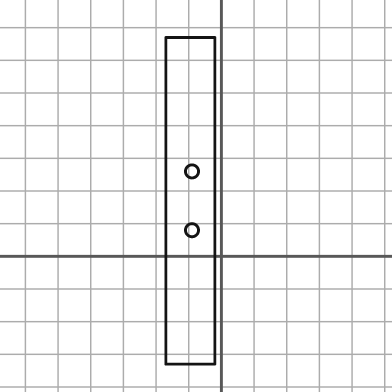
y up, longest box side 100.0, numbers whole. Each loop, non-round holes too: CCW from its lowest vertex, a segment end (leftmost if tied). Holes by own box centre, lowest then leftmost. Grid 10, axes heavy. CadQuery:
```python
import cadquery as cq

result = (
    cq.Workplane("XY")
    .moveTo(-17.0, -33.0)
    .lineTo(-2.0, -33.0)
    .lineTo(-2.0, 67.0)
    .lineTo(-17.0, 67.0)
    .close()
    .moveTo(-9.0, 8.0)
    .circle(2.0)
    .moveTo(-9.0, 26.0)
    .circle(2.0)
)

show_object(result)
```